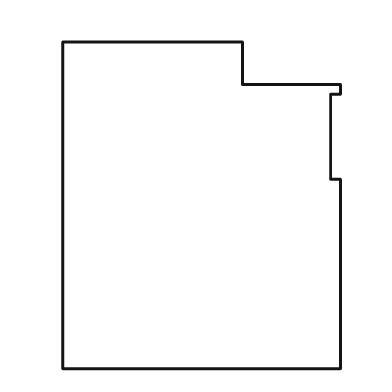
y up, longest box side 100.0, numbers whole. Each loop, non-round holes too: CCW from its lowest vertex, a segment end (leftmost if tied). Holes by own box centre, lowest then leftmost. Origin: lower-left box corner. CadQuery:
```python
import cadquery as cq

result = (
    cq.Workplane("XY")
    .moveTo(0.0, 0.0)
    .lineTo(85.0, 0.0)
    .lineTo(85.0, 58.0)
    .lineTo(82.0, 58.0)
    .lineTo(82.0, 84.0)
    .lineTo(85.0, 84.0)
    .lineTo(85.0, 87.0)
    .lineTo(55.0, 87.0)
    .lineTo(55.0, 100.0)
    .lineTo(0.0, 100.0)
    .close()
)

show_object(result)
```